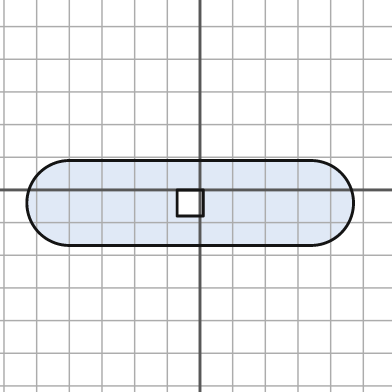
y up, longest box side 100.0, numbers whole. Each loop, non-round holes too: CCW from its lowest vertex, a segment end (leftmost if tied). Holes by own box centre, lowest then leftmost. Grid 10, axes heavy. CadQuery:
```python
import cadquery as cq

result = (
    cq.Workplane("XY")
    .moveTo(-40.0, -17.0)
    .lineTo(34.0, -17.0)
    .threePointArc((47.0, -4.0), (34.0, 9.0))
    .lineTo(-40.0, 9.0)
    .threePointArc((-53.0, -4.0), (-40.0, -17.0))
    .close()
    .moveTo(-7.0, -8.0)
    .lineTo(1.0, -8.0)
    .lineTo(1.0, 0.0)
    .lineTo(-7.0, 0.0)
    .close()
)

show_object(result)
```